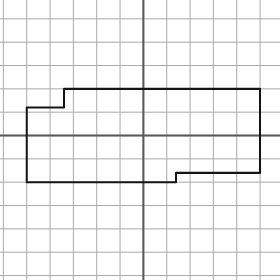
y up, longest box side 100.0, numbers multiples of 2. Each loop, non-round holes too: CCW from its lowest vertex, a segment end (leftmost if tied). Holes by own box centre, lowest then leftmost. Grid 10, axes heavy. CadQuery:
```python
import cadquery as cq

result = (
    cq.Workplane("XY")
    .moveTo(-50.0, -20.0)
    .lineTo(14.0, -20.0)
    .lineTo(14.0, -16.0)
    .lineTo(50.0, -16.0)
    .lineTo(50.0, 20.0)
    .lineTo(-34.0, 20.0)
    .lineTo(-34.0, 12.0)
    .lineTo(-50.0, 12.0)
    .close()
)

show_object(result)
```